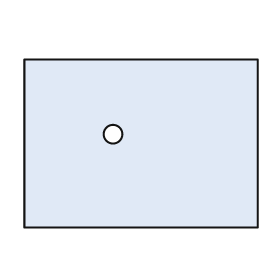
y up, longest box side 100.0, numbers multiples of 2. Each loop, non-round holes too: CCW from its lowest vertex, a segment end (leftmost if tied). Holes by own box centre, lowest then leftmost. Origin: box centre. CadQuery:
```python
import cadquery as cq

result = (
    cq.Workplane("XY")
    .moveTo(-50.0, -36.0)
    .lineTo(50.0, -36.0)
    .lineTo(50.0, 36.0)
    .lineTo(-50.0, 36.0)
    .close()
    .moveTo(-12.0, 4.0)
    .circle(4.0)
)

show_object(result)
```